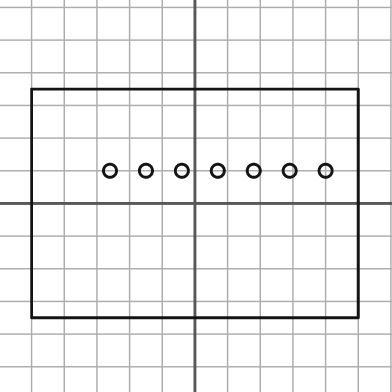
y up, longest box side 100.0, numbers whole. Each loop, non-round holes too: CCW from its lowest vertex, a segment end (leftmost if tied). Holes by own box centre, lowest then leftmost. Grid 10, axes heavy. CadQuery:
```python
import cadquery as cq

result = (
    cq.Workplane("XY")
    .moveTo(-50.0, -35.0)
    .lineTo(50.0, -35.0)
    .lineTo(50.0, 35.0)
    .lineTo(-50.0, 35.0)
    .close()
    .moveTo(-26.0, 10.0)
    .circle(2.0)
    .moveTo(-15.0, 10.0)
    .circle(2.0)
    .moveTo(-4.0, 10.0)
    .circle(2.0)
    .moveTo(7.0, 10.0)
    .circle(2.0)
    .moveTo(18.0, 10.0)
    .circle(2.0)
    .moveTo(29.0, 10.0)
    .circle(2.0)
    .moveTo(40.0, 10.0)
    .circle(2.0)
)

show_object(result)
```